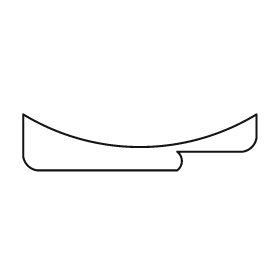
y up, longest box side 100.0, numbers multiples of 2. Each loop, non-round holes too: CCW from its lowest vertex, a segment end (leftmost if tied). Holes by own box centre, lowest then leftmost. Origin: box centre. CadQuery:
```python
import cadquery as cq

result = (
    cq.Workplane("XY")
    .moveTo(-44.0, -12.0)
    .lineTo(16.0, -12.0)
    .threePointArc((18.0, -8.0), (16.0, -4.0))
    .lineTo(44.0, -4.0)
    .threePointArc((48.0, -2.0), (50.0, 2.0))
    .lineTo(50.0, 12.0)
    .threePointArc((0.0, -2.0), (-50.0, 12.0))
    .lineTo(-50.0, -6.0)
    .threePointArc((-48.0, -10.0), (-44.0, -12.0))
    .close()
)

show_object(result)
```